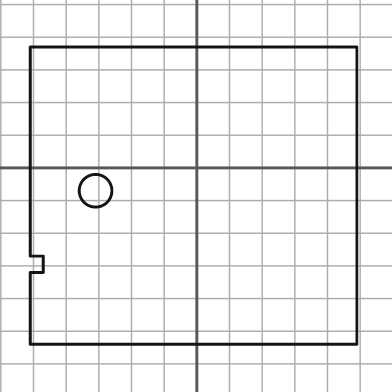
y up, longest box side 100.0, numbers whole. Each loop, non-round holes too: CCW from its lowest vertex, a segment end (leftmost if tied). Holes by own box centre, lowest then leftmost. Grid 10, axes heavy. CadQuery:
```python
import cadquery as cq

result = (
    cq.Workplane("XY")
    .moveTo(-51.0, -54.0)
    .lineTo(49.0, -54.0)
    .lineTo(49.0, 37.0)
    .lineTo(-51.0, 37.0)
    .lineTo(-51.0, -27.0)
    .lineTo(-47.0, -27.0)
    .lineTo(-47.0, -32.0)
    .lineTo(-51.0, -32.0)
    .close()
    .moveTo(-31.0, -7.0)
    .circle(5.0)
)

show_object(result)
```